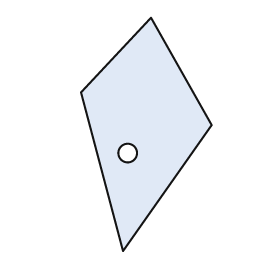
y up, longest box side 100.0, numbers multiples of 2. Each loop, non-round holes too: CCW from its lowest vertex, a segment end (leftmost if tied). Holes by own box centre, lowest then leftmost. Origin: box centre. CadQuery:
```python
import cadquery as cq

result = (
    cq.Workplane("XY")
    .moveTo(-10.0, -50.0)
    .lineTo(28.0, 4.0)
    .lineTo(2.0, 50.0)
    .lineTo(-28.0, 18.0)
    .close()
    .moveTo(-8.0, -8.0)
    .circle(4.0)
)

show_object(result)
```